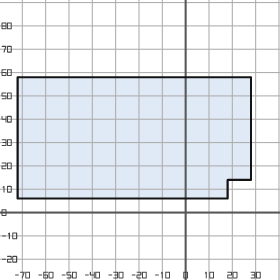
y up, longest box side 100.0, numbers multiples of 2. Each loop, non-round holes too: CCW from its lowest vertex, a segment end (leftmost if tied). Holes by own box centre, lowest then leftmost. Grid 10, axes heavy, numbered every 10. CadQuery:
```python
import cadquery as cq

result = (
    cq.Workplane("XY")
    .moveTo(-72.0, 6.0)
    .lineTo(18.0, 6.0)
    .lineTo(18.0, 14.0)
    .lineTo(28.0, 14.0)
    .lineTo(28.0, 58.0)
    .lineTo(-72.0, 58.0)
    .close()
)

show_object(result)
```